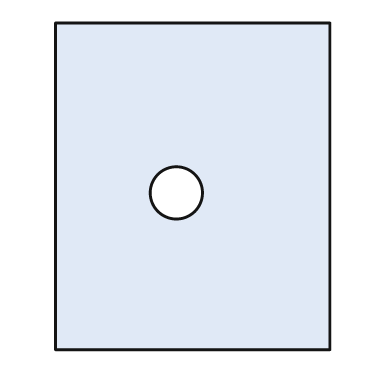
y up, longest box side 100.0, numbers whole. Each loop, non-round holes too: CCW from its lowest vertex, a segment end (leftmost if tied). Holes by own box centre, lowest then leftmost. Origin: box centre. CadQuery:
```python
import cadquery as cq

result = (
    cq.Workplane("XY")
    .moveTo(-42.0, -50.0)
    .lineTo(42.0, -50.0)
    .lineTo(42.0, 50.0)
    .lineTo(-42.0, 50.0)
    .close()
    .moveTo(-5.0, -2.0)
    .circle(8.0)
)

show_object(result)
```